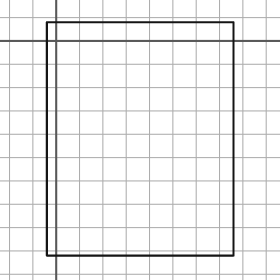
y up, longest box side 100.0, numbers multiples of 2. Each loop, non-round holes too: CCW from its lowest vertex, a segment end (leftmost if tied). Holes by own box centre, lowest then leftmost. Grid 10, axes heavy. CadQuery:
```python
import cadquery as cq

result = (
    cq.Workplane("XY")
    .moveTo(-4.0, -92.0)
    .lineTo(76.0, -92.0)
    .lineTo(76.0, 8.0)
    .lineTo(-4.0, 8.0)
    .close()
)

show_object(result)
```